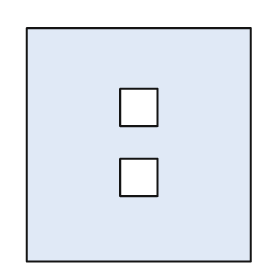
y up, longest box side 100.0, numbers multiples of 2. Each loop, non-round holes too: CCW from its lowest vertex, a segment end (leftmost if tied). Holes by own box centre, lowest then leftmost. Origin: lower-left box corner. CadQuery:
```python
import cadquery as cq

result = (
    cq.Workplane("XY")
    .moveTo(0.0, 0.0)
    .lineTo(96.0, 0.0)
    .lineTo(96.0, 100.0)
    .lineTo(0.0, 100.0)
    .close()
    .moveTo(40.0, 28.0)
    .lineTo(56.0, 28.0)
    .lineTo(56.0, 44.0)
    .lineTo(40.0, 44.0)
    .close()
    .moveTo(40.0, 58.0)
    .lineTo(56.0, 58.0)
    .lineTo(56.0, 74.0)
    .lineTo(40.0, 74.0)
    .close()
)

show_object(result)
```